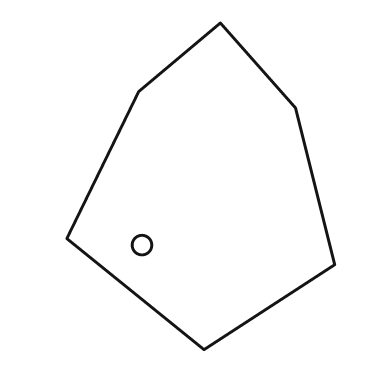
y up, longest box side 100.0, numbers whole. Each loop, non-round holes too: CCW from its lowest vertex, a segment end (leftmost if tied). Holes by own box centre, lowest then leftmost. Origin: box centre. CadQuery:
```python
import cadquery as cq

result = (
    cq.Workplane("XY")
    .moveTo(1.0, -50.0)
    .lineTo(41.0, -24.0)
    .lineTo(29.0, 24.0)
    .lineTo(6.0, 50.0)
    .lineTo(-19.0, 29.0)
    .lineTo(-41.0, -16.0)
    .close()
    .moveTo(-18.0, -18.0)
    .circle(3.0)
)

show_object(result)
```